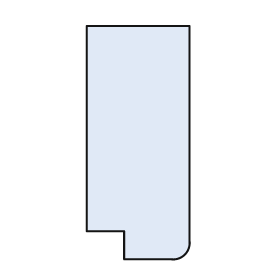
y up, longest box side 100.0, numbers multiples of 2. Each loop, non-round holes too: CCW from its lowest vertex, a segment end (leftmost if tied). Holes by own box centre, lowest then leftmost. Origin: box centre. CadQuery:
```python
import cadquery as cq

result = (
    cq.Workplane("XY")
    .moveTo(-6.0, -50.0)
    .lineTo(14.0, -50.0)
    .threePointArc((20.0, -48.0), (22.0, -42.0))
    .lineTo(22.0, 50.0)
    .lineTo(-22.0, 50.0)
    .lineTo(-22.0, -38.0)
    .lineTo(-6.0, -38.0)
    .close()
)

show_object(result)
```